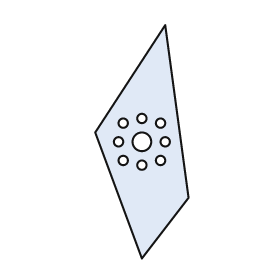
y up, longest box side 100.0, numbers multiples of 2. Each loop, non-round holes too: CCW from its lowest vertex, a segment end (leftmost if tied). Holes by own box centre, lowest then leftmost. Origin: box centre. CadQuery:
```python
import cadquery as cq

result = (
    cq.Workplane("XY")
    .moveTo(0.0, -50.0)
    .lineTo(20.0, -24.0)
    .lineTo(10.0, 50.0)
    .lineTo(-20.0, 4.0)
    .close()
    .moveTo(0.0, -10.0)
    .circle(2.0)
    .moveTo(-8.0, -8.0)
    .circle(2.0)
    .moveTo(8.0, -8.0)
    .circle(2.0)
    .moveTo(-10.0, 0.0)
    .circle(2.0)
    .moveTo(0.0, 0.0)
    .circle(4.0)
    .moveTo(10.0, 0.0)
    .circle(2.0)
    .moveTo(-8.0, 8.0)
    .circle(2.0)
    .moveTo(8.0, 8.0)
    .circle(2.0)
    .moveTo(0.0, 10.0)
    .circle(2.0)
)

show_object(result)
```